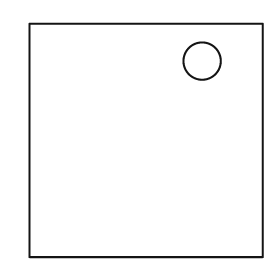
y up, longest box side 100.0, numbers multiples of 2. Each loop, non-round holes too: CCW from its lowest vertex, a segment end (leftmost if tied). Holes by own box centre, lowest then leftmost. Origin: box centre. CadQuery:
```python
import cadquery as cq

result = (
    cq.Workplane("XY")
    .moveTo(-50.0, -50.0)
    .lineTo(50.0, -50.0)
    .lineTo(50.0, 50.0)
    .lineTo(-50.0, 50.0)
    .close()
    .moveTo(24.0, 34.0)
    .circle(8.0)
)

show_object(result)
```